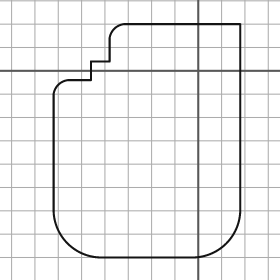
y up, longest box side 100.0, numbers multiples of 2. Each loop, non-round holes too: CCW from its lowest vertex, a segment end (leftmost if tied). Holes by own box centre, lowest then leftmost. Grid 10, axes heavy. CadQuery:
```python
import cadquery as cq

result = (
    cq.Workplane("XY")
    .moveTo(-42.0, -80.0)
    .lineTo(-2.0, -80.0)
    .threePointArc((12.0, -74.0), (18.0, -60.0))
    .lineTo(18.0, 20.0)
    .lineTo(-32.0, 20.0)
    .threePointArc((-36.0, 18.0), (-38.0, 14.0))
    .lineTo(-38.0, 4.0)
    .lineTo(-46.0, 4.0)
    .lineTo(-46.0, -4.0)
    .lineTo(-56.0, -4.0)
    .threePointArc((-60.0, -6.0), (-62.0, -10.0))
    .lineTo(-62.0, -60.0)
    .threePointArc((-56.0, -74.0), (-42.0, -80.0))
    .close()
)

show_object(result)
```